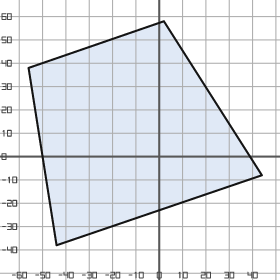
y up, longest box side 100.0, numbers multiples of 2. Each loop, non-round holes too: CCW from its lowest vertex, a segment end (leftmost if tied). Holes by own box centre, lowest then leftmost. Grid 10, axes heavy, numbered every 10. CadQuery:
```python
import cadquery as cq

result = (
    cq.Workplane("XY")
    .moveTo(-44.0, -38.0)
    .lineTo(44.0, -8.0)
    .lineTo(2.0, 58.0)
    .lineTo(-56.0, 38.0)
    .close()
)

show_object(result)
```